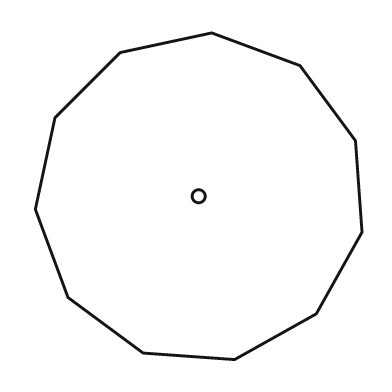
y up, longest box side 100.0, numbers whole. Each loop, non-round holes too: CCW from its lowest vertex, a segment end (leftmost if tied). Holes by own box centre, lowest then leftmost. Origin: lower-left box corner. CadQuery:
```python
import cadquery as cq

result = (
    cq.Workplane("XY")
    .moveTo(61.0, 0.0)
    .lineTo(86.0, 14.0)
    .lineTo(100.0, 39.0)
    .lineTo(98.0, 67.0)
    .lineTo(81.0, 90.0)
    .lineTo(54.0, 100.0)
    .lineTo(26.0, 94.0)
    .lineTo(6.0, 74.0)
    .lineTo(0.0, 46.0)
    .lineTo(10.0, 19.0)
    .lineTo(33.0, 2.0)
    .close()
    .moveTo(50.0, 50.0)
    .circle(2.0)
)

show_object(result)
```